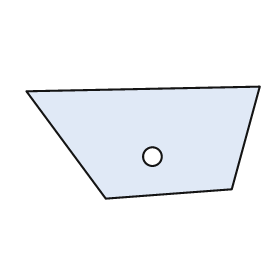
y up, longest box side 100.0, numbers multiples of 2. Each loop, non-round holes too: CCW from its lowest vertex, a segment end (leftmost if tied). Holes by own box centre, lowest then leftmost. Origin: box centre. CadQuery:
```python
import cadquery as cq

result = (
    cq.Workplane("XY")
    .moveTo(-16.0, -24.0)
    .lineTo(38.0, -20.0)
    .lineTo(50.0, 24.0)
    .lineTo(-50.0, 22.0)
    .close()
    .moveTo(4.0, -6.0)
    .circle(4.0)
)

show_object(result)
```